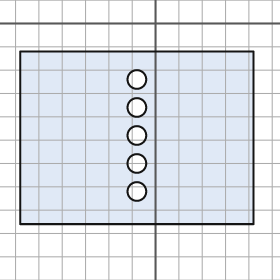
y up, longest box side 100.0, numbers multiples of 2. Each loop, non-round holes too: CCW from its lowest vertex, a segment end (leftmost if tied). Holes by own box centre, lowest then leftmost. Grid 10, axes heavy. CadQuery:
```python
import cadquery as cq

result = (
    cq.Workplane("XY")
    .moveTo(-58.0, -86.0)
    .lineTo(42.0, -86.0)
    .lineTo(42.0, -12.0)
    .lineTo(-58.0, -12.0)
    .close()
    .moveTo(-8.0, -72.0)
    .circle(4.0)
    .moveTo(-8.0, -60.0)
    .circle(4.0)
    .moveTo(-8.0, -48.0)
    .circle(4.0)
    .moveTo(-8.0, -36.0)
    .circle(4.0)
    .moveTo(-8.0, -24.0)
    .circle(4.0)
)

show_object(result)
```